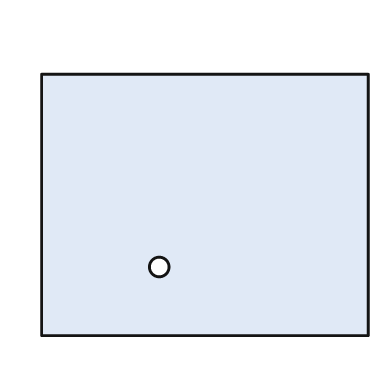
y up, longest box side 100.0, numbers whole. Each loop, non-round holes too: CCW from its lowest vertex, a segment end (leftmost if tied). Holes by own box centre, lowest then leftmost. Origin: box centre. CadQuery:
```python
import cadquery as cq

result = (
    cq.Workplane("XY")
    .moveTo(-50.0, -40.0)
    .lineTo(50.0, -40.0)
    .lineTo(50.0, 40.0)
    .lineTo(-50.0, 40.0)
    .close()
    .moveTo(-14.0, -19.0)
    .circle(3.0)
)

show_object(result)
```